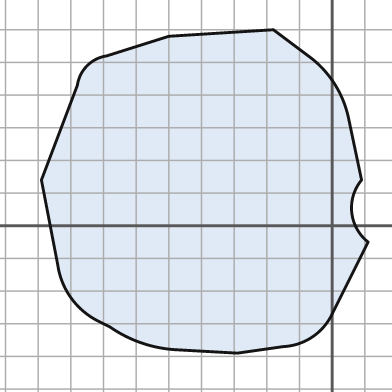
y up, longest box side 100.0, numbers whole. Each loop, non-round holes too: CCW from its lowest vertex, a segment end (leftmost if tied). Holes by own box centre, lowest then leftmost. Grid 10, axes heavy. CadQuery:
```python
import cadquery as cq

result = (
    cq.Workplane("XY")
    .moveTo(-29.0, -39.0)
    .lineTo(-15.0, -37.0)
    .threePointArc((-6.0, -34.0), (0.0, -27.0))
    .lineTo(11.0, -5.0)
    .threePointArc((6.0, 4.0), (9.0, 14.0))
    .lineTo(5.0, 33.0)
    .threePointArc((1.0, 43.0), (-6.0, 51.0))
    .lineTo(-18.0, 60.0)
    .lineTo(-50.0, 58.0)
    .lineTo(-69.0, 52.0)
    .threePointArc((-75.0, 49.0), (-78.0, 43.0))
    .lineTo(-89.0, 14.0)
    .lineTo(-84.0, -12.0)
    .threePointArc((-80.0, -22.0), (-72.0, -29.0))
    .lineTo(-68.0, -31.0)
    .threePointArc((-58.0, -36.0), (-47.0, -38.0))
    .close()
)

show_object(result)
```